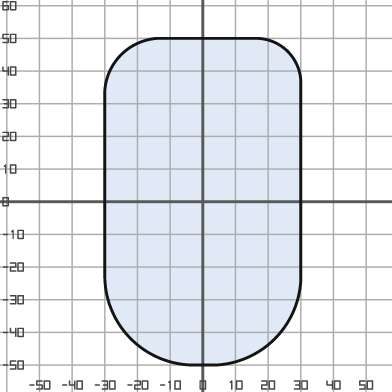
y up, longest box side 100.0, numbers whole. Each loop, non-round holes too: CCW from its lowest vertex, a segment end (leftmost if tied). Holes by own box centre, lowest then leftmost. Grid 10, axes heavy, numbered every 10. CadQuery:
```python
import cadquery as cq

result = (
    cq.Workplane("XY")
    .moveTo(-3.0, -50.0)
    .lineTo(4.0, -50.0)
    .threePointArc((22.0, -42.0), (30.0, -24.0))
    .lineTo(30.0, 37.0)
    .threePointArc((26.0, 46.0), (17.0, 50.0))
    .lineTo(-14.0, 50.0)
    .threePointArc((-25.0, 45.0), (-30.0, 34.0))
    .lineTo(-30.0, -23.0)
    .threePointArc((-22.0, -42.0), (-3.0, -50.0))
    .close()
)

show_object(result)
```